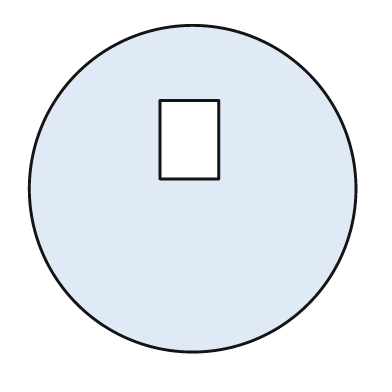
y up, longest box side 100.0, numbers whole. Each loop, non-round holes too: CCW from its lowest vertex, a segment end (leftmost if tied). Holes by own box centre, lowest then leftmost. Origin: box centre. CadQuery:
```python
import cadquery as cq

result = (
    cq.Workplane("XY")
    .moveTo(0.0, 0.0)
    .circle(50.0)
    .moveTo(-10.0, 3.0)
    .lineTo(8.0, 3.0)
    .lineTo(8.0, 27.0)
    .lineTo(-10.0, 27.0)
    .close()
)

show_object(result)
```